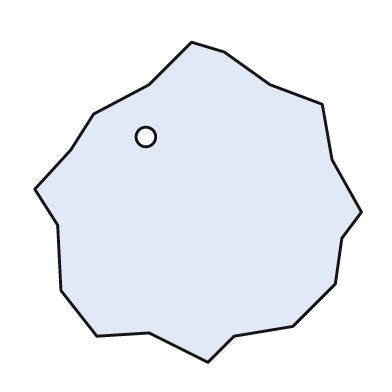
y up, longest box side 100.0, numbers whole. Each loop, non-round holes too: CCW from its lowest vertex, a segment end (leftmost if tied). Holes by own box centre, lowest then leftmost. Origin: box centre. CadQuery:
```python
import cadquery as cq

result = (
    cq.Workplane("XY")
    .moveTo(3.0, -49.0)
    .lineTo(11.0, -41.0)
    .lineTo(29.0, -38.0)
    .lineTo(42.0, -25.0)
    .lineTo(44.0, -11.0)
    .lineTo(50.0, -3.0)
    .lineTo(41.0, 13.0)
    .lineTo(38.0, 30.0)
    .lineTo(22.0, 36.0)
    .lineTo(8.0, 46.0)
    .lineTo(-2.0, 49.0)
    .lineTo(-15.0, 36.0)
    .lineTo(-32.0, 27.0)
    .lineTo(-39.0, 16.0)
    .lineTo(-50.0, 4.0)
    .lineTo(-43.0, -7.0)
    .lineTo(-42.0, -27.0)
    .lineTo(-31.0, -41.0)
    .lineTo(-15.0, -40.0)
    .close()
    .moveTo(-16.0, 20.0)
    .circle(3.0)
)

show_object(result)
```